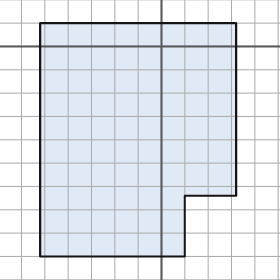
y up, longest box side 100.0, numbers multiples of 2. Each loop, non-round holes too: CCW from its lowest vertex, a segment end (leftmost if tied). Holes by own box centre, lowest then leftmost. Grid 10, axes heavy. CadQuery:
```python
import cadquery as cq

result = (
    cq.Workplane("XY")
    .moveTo(-52.0, -90.0)
    .lineTo(10.0, -90.0)
    .lineTo(10.0, -64.0)
    .lineTo(32.0, -64.0)
    .lineTo(32.0, 10.0)
    .lineTo(-52.0, 10.0)
    .close()
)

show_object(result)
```